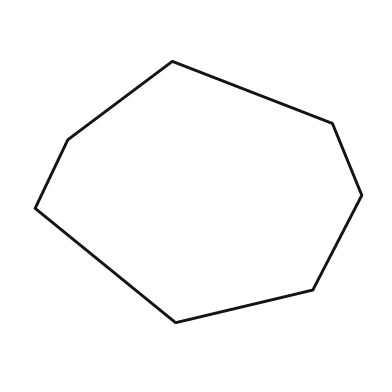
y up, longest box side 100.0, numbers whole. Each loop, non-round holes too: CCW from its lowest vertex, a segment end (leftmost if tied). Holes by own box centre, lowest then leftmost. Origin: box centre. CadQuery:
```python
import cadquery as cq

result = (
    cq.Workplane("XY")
    .moveTo(-7.0, -40.0)
    .lineTo(35.0, -30.0)
    .lineTo(50.0, -1.0)
    .lineTo(41.0, 21.0)
    .lineTo(-8.0, 40.0)
    .lineTo(-40.0, 16.0)
    .lineTo(-50.0, -5.0)
    .close()
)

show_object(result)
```